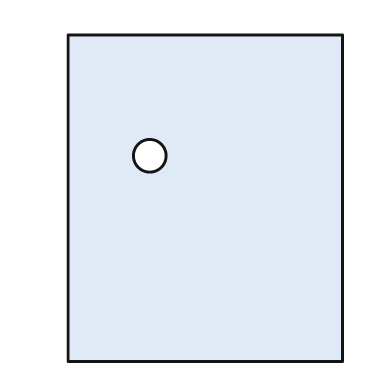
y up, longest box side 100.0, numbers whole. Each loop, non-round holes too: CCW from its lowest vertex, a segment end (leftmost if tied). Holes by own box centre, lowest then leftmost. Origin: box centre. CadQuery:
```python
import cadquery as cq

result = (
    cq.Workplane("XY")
    .moveTo(-42.0, -50.0)
    .lineTo(42.0, -50.0)
    .lineTo(42.0, 50.0)
    .lineTo(-42.0, 50.0)
    .close()
    .moveTo(-17.0, 13.0)
    .circle(5.0)
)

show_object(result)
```